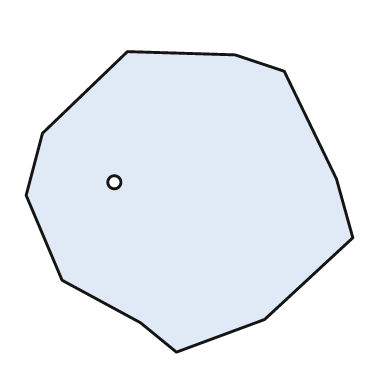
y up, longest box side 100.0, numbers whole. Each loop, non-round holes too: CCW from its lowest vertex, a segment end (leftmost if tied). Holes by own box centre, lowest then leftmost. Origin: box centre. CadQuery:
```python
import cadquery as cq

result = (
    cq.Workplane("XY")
    .moveTo(-4.0, -46.0)
    .lineTo(23.0, -36.0)
    .lineTo(50.0, -11.0)
    .lineTo(45.0, 7.0)
    .lineTo(29.0, 40.0)
    .lineTo(14.0, 45.0)
    .lineTo(-19.0, 46.0)
    .lineTo(-45.0, 21.0)
    .lineTo(-50.0, 2.0)
    .lineTo(-39.0, -24.0)
    .lineTo(-15.0, -37.0)
    .close()
    .moveTo(-23.0, 6.0)
    .circle(2.0)
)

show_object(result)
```